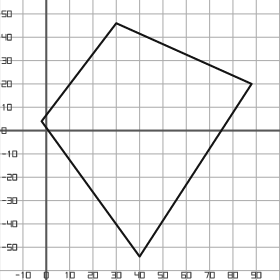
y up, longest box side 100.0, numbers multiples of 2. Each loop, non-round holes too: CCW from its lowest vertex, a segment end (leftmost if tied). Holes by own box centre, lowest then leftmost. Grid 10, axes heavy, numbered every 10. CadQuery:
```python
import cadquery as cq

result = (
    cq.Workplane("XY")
    .moveTo(40.0, -54.0)
    .lineTo(88.0, 20.0)
    .lineTo(30.0, 46.0)
    .lineTo(-2.0, 4.0)
    .close()
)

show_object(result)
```